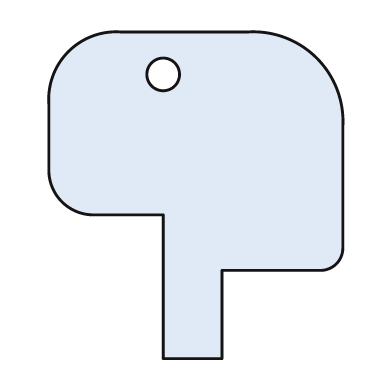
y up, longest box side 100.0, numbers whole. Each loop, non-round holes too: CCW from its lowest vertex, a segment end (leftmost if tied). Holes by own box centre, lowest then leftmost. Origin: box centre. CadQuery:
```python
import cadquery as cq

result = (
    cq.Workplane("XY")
    .moveTo(-10.0, -50.0)
    .lineTo(8.0, -50.0)
    .lineTo(8.0, -23.0)
    .lineTo(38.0, -23.0)
    .threePointArc((43.0, -21.0), (45.0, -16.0))
    .lineTo(45.0, 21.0)
    .threePointArc((37.0, 42.0), (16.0, 50.0))
    .lineTo(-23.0, 50.0)
    .threePointArc((-39.0, 44.0), (-45.0, 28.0))
    .lineTo(-45.0, 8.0)
    .threePointArc((-41.0, -2.0), (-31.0, -6.0))
    .lineTo(-10.0, -6.0)
    .close()
    .moveTo(-10.0, 37.0)
    .circle(5.0)
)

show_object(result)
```